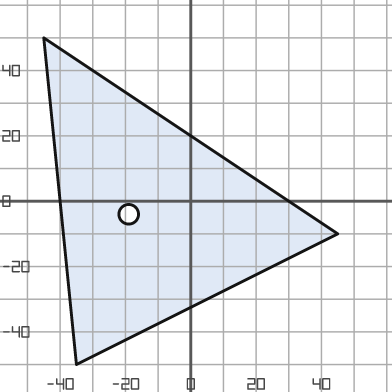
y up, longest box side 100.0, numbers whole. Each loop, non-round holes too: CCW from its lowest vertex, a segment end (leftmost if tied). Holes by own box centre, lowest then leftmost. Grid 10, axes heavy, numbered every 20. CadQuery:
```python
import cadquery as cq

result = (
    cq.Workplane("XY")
    .moveTo(-35.0, -50.0)
    .lineTo(45.0, -10.0)
    .lineTo(-45.0, 50.0)
    .close()
    .moveTo(-19.0, -4.0)
    .circle(3.0)
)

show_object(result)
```